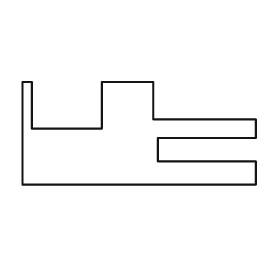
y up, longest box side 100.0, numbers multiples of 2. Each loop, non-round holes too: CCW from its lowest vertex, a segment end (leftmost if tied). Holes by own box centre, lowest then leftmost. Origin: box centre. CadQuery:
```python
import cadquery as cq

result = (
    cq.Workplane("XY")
    .moveTo(-50.0, -22.0)
    .lineTo(50.0, -22.0)
    .lineTo(50.0, -12.0)
    .lineTo(8.0, -12.0)
    .lineTo(8.0, -2.0)
    .lineTo(50.0, -2.0)
    .lineTo(50.0, 6.0)
    .lineTo(6.0, 6.0)
    .lineTo(6.0, 22.0)
    .lineTo(-16.0, 22.0)
    .lineTo(-16.0, 2.0)
    .lineTo(-46.0, 2.0)
    .lineTo(-46.0, 22.0)
    .lineTo(-50.0, 22.0)
    .close()
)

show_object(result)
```